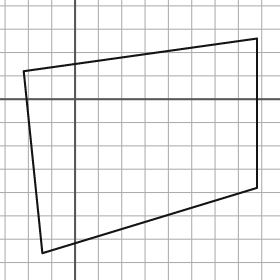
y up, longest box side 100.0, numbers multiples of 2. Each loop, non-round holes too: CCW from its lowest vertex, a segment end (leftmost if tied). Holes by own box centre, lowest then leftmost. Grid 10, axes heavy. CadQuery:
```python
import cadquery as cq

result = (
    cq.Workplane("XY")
    .moveTo(-14.0, -66.0)
    .lineTo(78.0, -38.0)
    .lineTo(78.0, 26.0)
    .lineTo(-22.0, 12.0)
    .close()
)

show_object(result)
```